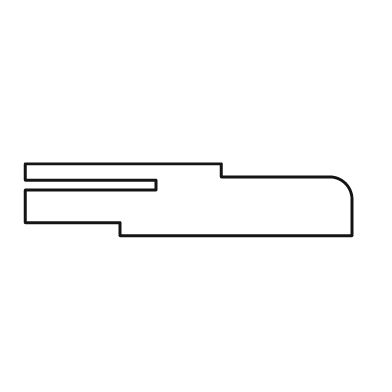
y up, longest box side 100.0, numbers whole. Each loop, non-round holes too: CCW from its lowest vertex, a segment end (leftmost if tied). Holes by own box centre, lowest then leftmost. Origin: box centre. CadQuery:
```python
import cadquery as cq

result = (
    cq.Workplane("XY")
    .moveTo(-21.0, -11.0)
    .lineTo(50.0, -11.0)
    .lineTo(50.0, 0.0)
    .threePointArc((48.0, 5.0), (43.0, 7.0))
    .lineTo(10.0, 7.0)
    .lineTo(10.0, 11.0)
    .lineTo(-50.0, 11.0)
    .lineTo(-50.0, 6.0)
    .lineTo(-10.0, 6.0)
    .lineTo(-10.0, 3.0)
    .lineTo(-50.0, 3.0)
    .lineTo(-50.0, -7.0)
    .lineTo(-21.0, -7.0)
    .close()
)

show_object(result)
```